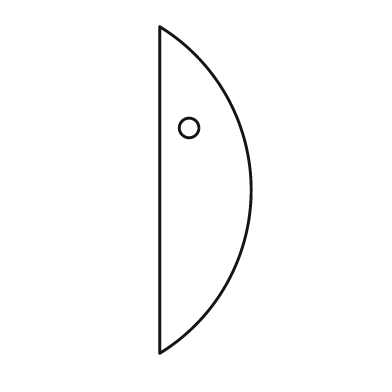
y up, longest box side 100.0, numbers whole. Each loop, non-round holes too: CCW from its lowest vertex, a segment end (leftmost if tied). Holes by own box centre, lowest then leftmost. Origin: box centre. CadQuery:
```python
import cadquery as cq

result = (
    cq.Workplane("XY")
    .moveTo(-14.0, -50.0)
    .threePointArc((14.0, 0.0), (-14.0, 50.0))
    .close()
    .moveTo(-5.0, 19.0)
    .circle(3.0)
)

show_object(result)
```